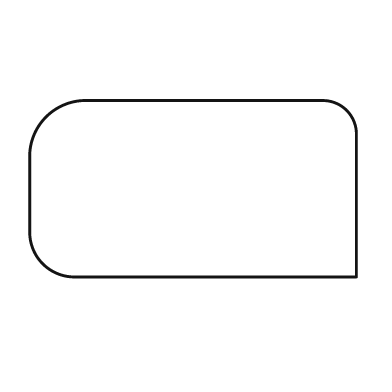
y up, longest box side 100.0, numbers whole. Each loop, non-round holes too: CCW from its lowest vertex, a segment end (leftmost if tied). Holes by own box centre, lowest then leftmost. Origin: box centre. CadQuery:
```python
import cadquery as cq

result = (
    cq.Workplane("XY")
    .moveTo(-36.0, -27.0)
    .lineTo(50.0, -27.0)
    .lineTo(50.0, 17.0)
    .threePointArc((47.0, 24.0), (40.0, 27.0))
    .lineTo(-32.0, 27.0)
    .threePointArc((-45.0, 22.0), (-50.0, 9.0))
    .lineTo(-50.0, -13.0)
    .threePointArc((-46.0, -23.0), (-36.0, -27.0))
    .close()
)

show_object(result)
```